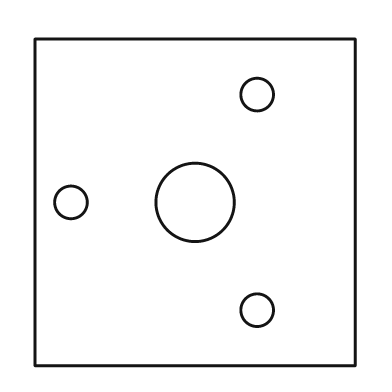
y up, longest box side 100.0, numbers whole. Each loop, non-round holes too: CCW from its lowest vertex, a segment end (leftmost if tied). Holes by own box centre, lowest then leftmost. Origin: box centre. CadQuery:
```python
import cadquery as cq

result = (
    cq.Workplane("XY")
    .moveTo(-49.0, -50.0)
    .lineTo(49.0, -50.0)
    .lineTo(49.0, 50.0)
    .lineTo(-49.0, 50.0)
    .close()
    .moveTo(19.0, -33.0)
    .circle(5.0)
    .moveTo(-38.0, 0.0)
    .circle(5.0)
    .moveTo(0.0, 0.0)
    .circle(12.0)
    .moveTo(19.0, 33.0)
    .circle(5.0)
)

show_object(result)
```